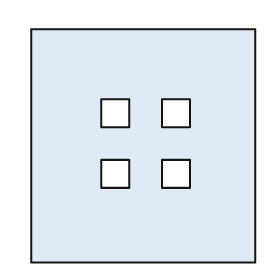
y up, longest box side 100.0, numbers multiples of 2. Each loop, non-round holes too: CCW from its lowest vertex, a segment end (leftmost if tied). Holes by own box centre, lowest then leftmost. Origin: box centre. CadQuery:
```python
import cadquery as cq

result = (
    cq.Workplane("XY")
    .moveTo(-48.0, -50.0)
    .lineTo(48.0, -50.0)
    .lineTo(48.0, 50.0)
    .lineTo(-48.0, 50.0)
    .close()
    .moveTo(-18.0, -18.0)
    .lineTo(-6.0, -18.0)
    .lineTo(-6.0, -6.0)
    .lineTo(-18.0, -6.0)
    .close()
    .moveTo(8.0, -18.0)
    .lineTo(20.0, -18.0)
    .lineTo(20.0, -6.0)
    .lineTo(8.0, -6.0)
    .close()
    .moveTo(-18.0, 8.0)
    .lineTo(-6.0, 8.0)
    .lineTo(-6.0, 20.0)
    .lineTo(-18.0, 20.0)
    .close()
    .moveTo(8.0, 8.0)
    .lineTo(20.0, 8.0)
    .lineTo(20.0, 20.0)
    .lineTo(8.0, 20.0)
    .close()
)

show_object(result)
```